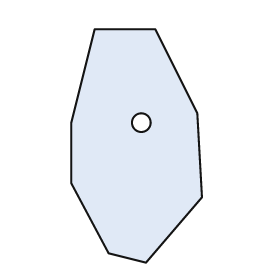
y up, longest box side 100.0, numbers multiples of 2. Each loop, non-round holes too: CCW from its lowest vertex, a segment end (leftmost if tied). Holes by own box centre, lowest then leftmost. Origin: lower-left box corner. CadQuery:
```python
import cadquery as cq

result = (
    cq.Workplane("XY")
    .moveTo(32.0, 0.0)
    .lineTo(56.0, 28.0)
    .lineTo(54.0, 64.0)
    .lineTo(36.0, 100.0)
    .lineTo(10.0, 100.0)
    .lineTo(0.0, 60.0)
    .lineTo(0.0, 34.0)
    .lineTo(16.0, 4.0)
    .close()
    .moveTo(30.0, 60.0)
    .circle(4.0)
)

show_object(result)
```